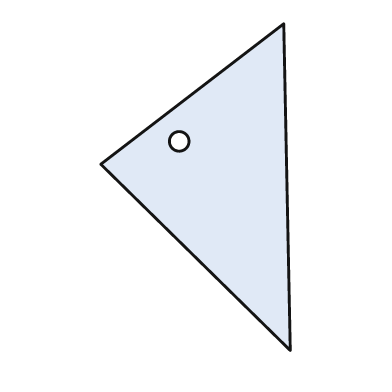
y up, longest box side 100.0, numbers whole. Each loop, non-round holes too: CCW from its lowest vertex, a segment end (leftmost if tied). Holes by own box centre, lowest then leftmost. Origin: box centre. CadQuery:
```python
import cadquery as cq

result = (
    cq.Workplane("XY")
    .moveTo(29.0, -50.0)
    .lineTo(27.0, 50.0)
    .lineTo(-29.0, 7.0)
    .close()
    .moveTo(-5.0, 14.0)
    .circle(3.0)
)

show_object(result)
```